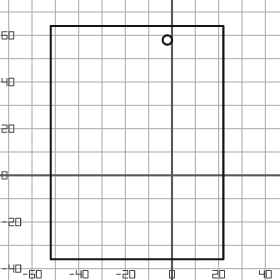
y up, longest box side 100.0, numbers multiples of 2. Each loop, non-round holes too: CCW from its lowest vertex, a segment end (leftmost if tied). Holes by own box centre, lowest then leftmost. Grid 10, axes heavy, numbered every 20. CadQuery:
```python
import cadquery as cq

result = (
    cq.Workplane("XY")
    .moveTo(-52.0, -36.0)
    .lineTo(22.0, -36.0)
    .lineTo(22.0, 64.0)
    .lineTo(-52.0, 64.0)
    .close()
    .moveTo(-2.0, 58.0)
    .circle(2.0)
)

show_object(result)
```